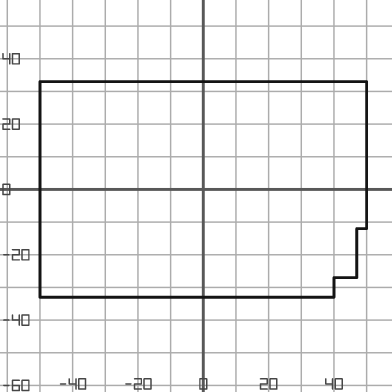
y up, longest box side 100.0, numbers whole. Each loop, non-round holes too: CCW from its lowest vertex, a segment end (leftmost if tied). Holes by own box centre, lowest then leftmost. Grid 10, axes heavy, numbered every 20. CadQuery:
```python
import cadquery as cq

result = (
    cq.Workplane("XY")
    .moveTo(-50.0, -33.0)
    .lineTo(40.0, -33.0)
    .lineTo(40.0, -27.0)
    .lineTo(47.0, -27.0)
    .lineTo(47.0, -12.0)
    .lineTo(50.0, -12.0)
    .lineTo(50.0, 33.0)
    .lineTo(-50.0, 33.0)
    .close()
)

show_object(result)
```